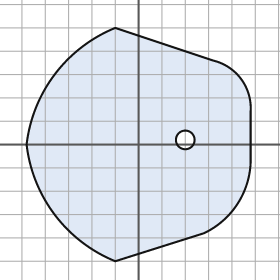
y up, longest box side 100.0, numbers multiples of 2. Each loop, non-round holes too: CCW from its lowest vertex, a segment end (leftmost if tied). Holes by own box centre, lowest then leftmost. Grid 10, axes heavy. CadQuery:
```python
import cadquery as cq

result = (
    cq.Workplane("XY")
    .moveTo(-10.0, -50.0)
    .lineTo(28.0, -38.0)
    .threePointArc((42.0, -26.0), (48.0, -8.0))
    .lineTo(48.0, 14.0)
    .threePointArc((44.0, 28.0), (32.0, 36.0))
    .lineTo(-10.0, 50.0)
    .threePointArc((-36.0, 30.0), (-48.0, 0.0))
    .threePointArc((-36.0, -30.0), (-10.0, -50.0))
    .close()
    .moveTo(20.0, 2.0)
    .circle(4.0)
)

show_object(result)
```